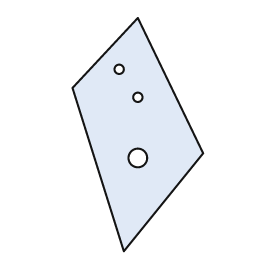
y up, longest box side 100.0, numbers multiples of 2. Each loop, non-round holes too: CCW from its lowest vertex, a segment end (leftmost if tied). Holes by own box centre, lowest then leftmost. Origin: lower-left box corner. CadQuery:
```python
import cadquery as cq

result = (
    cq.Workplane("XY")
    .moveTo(22.0, 0.0)
    .lineTo(56.0, 42.0)
    .lineTo(28.0, 100.0)
    .lineTo(0.0, 70.0)
    .close()
    .moveTo(28.0, 40.0)
    .circle(4.0)
    .moveTo(28.0, 66.0)
    .circle(2.0)
    .moveTo(20.0, 78.0)
    .circle(2.0)
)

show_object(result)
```